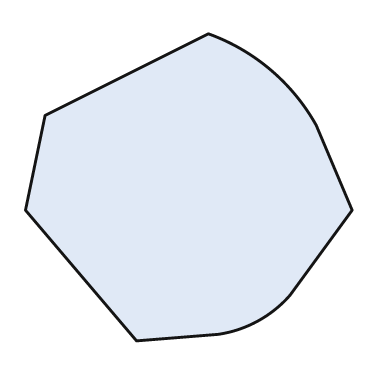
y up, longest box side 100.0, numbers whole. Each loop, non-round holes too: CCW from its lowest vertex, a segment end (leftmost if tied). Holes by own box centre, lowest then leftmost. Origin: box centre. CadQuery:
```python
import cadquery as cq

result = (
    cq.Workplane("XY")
    .moveTo(-16.0, -47.0)
    .lineTo(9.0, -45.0)
    .threePointArc((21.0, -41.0), (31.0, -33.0))
    .lineTo(50.0, -7.0)
    .lineTo(39.0, 19.0)
    .threePointArc((25.0, 36.0), (6.0, 47.0))
    .lineTo(-44.0, 22.0)
    .lineTo(-50.0, -7.0)
    .close()
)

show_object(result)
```